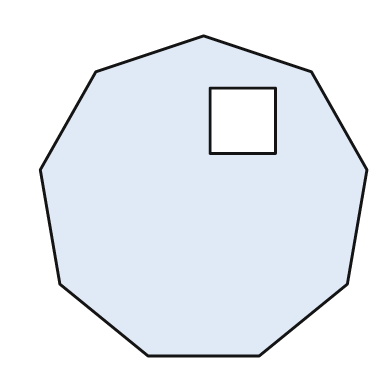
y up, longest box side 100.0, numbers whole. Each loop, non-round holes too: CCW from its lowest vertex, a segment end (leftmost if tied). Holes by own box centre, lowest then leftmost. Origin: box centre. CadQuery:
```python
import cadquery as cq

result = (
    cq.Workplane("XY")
    .moveTo(-17.0, -49.0)
    .lineTo(17.0, -49.0)
    .lineTo(44.0, -27.0)
    .lineTo(50.0, 8.0)
    .lineTo(33.0, 38.0)
    .lineTo(0.0, 49.0)
    .lineTo(-33.0, 38.0)
    .lineTo(-50.0, 8.0)
    .lineTo(-44.0, -27.0)
    .close()
    .moveTo(2.0, 13.0)
    .lineTo(22.0, 13.0)
    .lineTo(22.0, 33.0)
    .lineTo(2.0, 33.0)
    .close()
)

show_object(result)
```